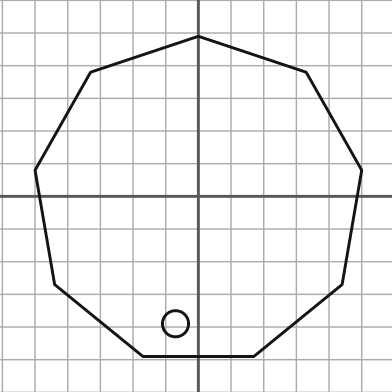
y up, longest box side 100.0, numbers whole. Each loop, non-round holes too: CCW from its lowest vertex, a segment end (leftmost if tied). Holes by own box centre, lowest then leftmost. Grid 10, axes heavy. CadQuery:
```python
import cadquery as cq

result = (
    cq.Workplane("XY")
    .moveTo(-17.0, -49.0)
    .lineTo(17.0, -49.0)
    .lineTo(44.0, -27.0)
    .lineTo(50.0, 8.0)
    .lineTo(33.0, 38.0)
    .lineTo(0.0, 49.0)
    .lineTo(-33.0, 38.0)
    .lineTo(-50.0, 8.0)
    .lineTo(-44.0, -27.0)
    .close()
    .moveTo(-7.0, -39.0)
    .circle(4.0)
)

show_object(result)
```